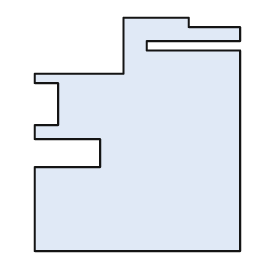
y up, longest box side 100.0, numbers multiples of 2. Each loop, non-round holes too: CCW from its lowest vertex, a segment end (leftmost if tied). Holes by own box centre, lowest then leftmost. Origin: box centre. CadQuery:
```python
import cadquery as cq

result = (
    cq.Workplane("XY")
    .moveTo(-44.0, -50.0)
    .lineTo(44.0, -50.0)
    .lineTo(44.0, 36.0)
    .lineTo(4.0, 36.0)
    .lineTo(4.0, 40.0)
    .lineTo(44.0, 40.0)
    .lineTo(44.0, 46.0)
    .lineTo(22.0, 46.0)
    .lineTo(22.0, 50.0)
    .lineTo(-6.0, 50.0)
    .lineTo(-6.0, 26.0)
    .lineTo(-44.0, 26.0)
    .lineTo(-44.0, 22.0)
    .lineTo(-34.0, 22.0)
    .lineTo(-34.0, 4.0)
    .lineTo(-44.0, 4.0)
    .lineTo(-44.0, -2.0)
    .lineTo(-16.0, -2.0)
    .lineTo(-16.0, -14.0)
    .lineTo(-44.0, -14.0)
    .close()
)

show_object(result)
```